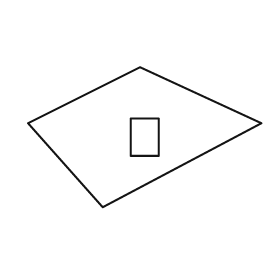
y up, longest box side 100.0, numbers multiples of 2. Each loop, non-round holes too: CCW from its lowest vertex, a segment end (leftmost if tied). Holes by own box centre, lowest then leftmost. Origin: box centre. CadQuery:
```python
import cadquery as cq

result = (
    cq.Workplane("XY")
    .moveTo(-18.0, -30.0)
    .lineTo(50.0, 6.0)
    .lineTo(-2.0, 30.0)
    .lineTo(-50.0, 6.0)
    .close()
    .moveTo(-6.0, -8.0)
    .lineTo(6.0, -8.0)
    .lineTo(6.0, 8.0)
    .lineTo(-6.0, 8.0)
    .close()
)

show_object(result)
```